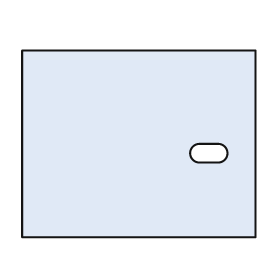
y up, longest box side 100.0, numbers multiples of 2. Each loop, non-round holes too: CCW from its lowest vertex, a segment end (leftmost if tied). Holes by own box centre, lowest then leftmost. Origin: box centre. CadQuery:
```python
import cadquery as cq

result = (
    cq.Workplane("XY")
    .moveTo(-50.0, -40.0)
    .lineTo(50.0, -40.0)
    .lineTo(50.0, 40.0)
    .lineTo(-50.0, 40.0)
    .close()
    .moveTo(26.0, -8.0)
    .lineTo(34.0, -8.0)
    .threePointArc((38.0, -4.0), (34.0, 0.0))
    .lineTo(26.0, 0.0)
    .threePointArc((22.0, -4.0), (26.0, -8.0))
    .close()
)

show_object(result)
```